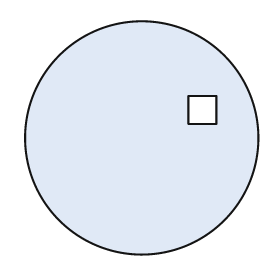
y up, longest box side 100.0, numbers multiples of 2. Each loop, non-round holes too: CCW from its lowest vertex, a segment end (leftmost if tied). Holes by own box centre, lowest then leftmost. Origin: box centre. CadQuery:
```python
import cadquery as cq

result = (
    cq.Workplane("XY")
    .moveTo(0.0, 0.0)
    .circle(50.0)
    .moveTo(20.0, 6.0)
    .lineTo(32.0, 6.0)
    .lineTo(32.0, 18.0)
    .lineTo(20.0, 18.0)
    .close()
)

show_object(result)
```